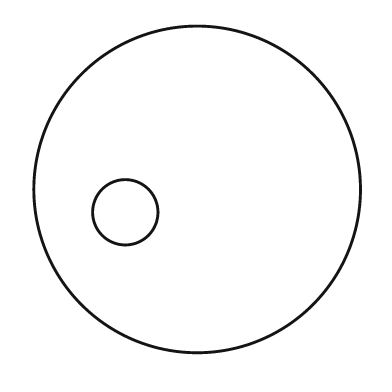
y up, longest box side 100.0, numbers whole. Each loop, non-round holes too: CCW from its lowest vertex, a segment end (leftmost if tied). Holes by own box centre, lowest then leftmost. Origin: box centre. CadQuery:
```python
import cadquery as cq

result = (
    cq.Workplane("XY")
    .moveTo(0.0, 0.0)
    .circle(50.0)
    .moveTo(-22.0, -7.0)
    .circle(10.0)
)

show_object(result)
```